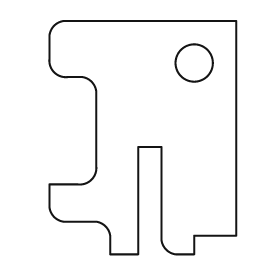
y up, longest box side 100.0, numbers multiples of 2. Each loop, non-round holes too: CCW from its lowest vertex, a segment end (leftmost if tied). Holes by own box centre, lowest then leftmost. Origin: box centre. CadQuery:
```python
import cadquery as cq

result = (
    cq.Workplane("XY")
    .moveTo(-14.0, -50.0)
    .lineTo(-2.0, -50.0)
    .lineTo(-2.0, -4.0)
    .lineTo(8.0, -4.0)
    .lineTo(8.0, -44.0)
    .threePointArc((10.0, -48.0), (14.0, -50.0))
    .lineTo(22.0, -50.0)
    .lineTo(22.0, -42.0)
    .lineTo(40.0, -42.0)
    .lineTo(40.0, 50.0)
    .lineTo(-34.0, 50.0)
    .threePointArc((-38.0, 48.0), (-40.0, 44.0))
    .lineTo(-40.0, 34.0)
    .threePointArc((-38.0, 28.0), (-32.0, 26.0))
    .lineTo(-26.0, 26.0)
    .threePointArc((-22.0, 24.0), (-20.0, 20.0))
    .lineTo(-20.0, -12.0)
    .threePointArc((-22.0, -18.0), (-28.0, -20.0))
    .lineTo(-40.0, -20.0)
    .lineTo(-40.0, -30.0)
    .threePointArc((-38.0, -34.0), (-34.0, -36.0))
    .lineTo(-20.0, -36.0)
    .threePointArc((-16.0, -38.0), (-14.0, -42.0))
    .close()
    .moveTo(22.0, 32.0)
    .circle(8.0)
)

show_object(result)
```